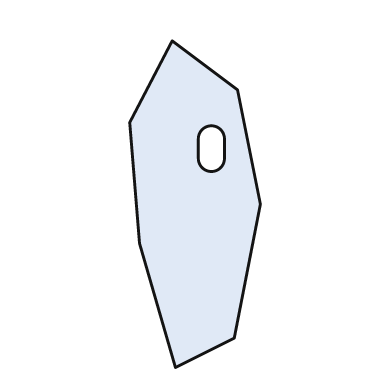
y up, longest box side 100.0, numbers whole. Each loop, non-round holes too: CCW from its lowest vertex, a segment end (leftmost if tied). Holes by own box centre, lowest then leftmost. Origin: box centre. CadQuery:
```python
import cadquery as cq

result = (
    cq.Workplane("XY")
    .moveTo(-6.0, -50.0)
    .lineTo(12.0, -41.0)
    .lineTo(20.0, 0.0)
    .lineTo(13.0, 35.0)
    .lineTo(-7.0, 50.0)
    .lineTo(-20.0, 25.0)
    .lineTo(-17.0, -12.0)
    .close()
    .moveTo(1.0, 14.0)
    .threePointArc((5.0, 10.0), (9.0, 14.0))
    .lineTo(9.0, 20.0)
    .threePointArc((5.0, 24.0), (1.0, 20.0))
    .close()
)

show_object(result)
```